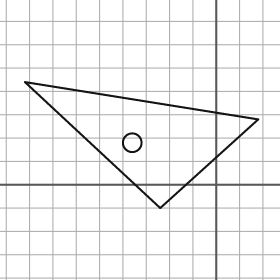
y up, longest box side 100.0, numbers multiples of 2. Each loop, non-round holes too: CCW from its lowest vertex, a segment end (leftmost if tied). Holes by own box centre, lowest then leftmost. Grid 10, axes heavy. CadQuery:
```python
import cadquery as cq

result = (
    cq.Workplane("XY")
    .moveTo(-24.0, -10.0)
    .lineTo(18.0, 28.0)
    .lineTo(-82.0, 44.0)
    .close()
    .moveTo(-36.0, 18.0)
    .circle(4.0)
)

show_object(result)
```